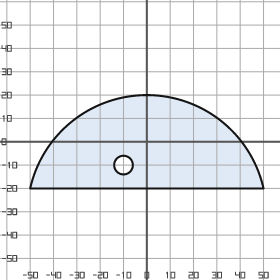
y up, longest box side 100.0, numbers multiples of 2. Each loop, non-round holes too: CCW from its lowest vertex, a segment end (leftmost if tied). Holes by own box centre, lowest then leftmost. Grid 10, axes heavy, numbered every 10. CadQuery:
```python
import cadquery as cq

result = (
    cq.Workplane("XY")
    .moveTo(-50.0, -20.0)
    .lineTo(50.0, -20.0)
    .threePointArc((0.0, 20.0), (-50.0, -20.0))
    .close()
    .moveTo(-10.0, -10.0)
    .circle(4.0)
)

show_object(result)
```